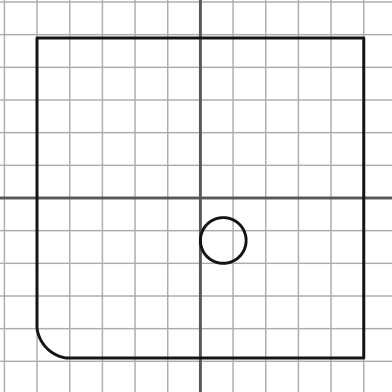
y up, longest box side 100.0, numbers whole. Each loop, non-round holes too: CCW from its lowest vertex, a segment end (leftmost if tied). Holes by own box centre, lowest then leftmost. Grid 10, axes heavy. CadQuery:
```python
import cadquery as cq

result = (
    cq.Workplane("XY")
    .moveTo(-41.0, -49.0)
    .lineTo(50.0, -49.0)
    .lineTo(50.0, 49.0)
    .lineTo(-50.0, 49.0)
    .lineTo(-50.0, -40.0)
    .threePointArc((-47.0, -46.0), (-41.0, -49.0))
    .close()
    .moveTo(7.0, -13.0)
    .circle(7.0)
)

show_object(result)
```